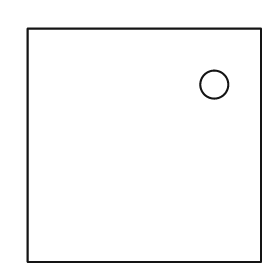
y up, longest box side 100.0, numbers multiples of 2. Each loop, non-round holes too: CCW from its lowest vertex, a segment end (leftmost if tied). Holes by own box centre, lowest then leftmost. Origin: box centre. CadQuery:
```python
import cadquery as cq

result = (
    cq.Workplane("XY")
    .moveTo(-50.0, -50.0)
    .lineTo(50.0, -50.0)
    .lineTo(50.0, 50.0)
    .lineTo(-50.0, 50.0)
    .close()
    .moveTo(30.0, 26.0)
    .circle(6.0)
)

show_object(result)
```